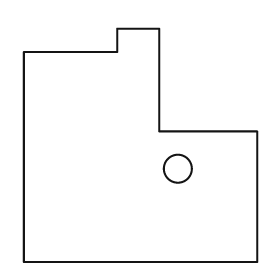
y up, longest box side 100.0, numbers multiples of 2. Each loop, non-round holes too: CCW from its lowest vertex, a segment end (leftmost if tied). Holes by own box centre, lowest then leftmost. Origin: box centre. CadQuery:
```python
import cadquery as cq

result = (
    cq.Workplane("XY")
    .moveTo(-50.0, -50.0)
    .lineTo(50.0, -50.0)
    .lineTo(50.0, 6.0)
    .lineTo(8.0, 6.0)
    .lineTo(8.0, 50.0)
    .lineTo(-10.0, 50.0)
    .lineTo(-10.0, 40.0)
    .lineTo(-50.0, 40.0)
    .close()
    .moveTo(16.0, -10.0)
    .circle(6.0)
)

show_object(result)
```